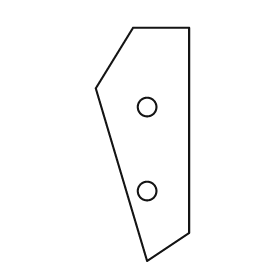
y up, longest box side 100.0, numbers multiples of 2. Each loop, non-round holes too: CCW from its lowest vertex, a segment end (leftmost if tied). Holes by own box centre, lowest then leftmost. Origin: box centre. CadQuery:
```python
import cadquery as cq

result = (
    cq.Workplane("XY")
    .moveTo(2.0, -50.0)
    .lineTo(20.0, -38.0)
    .lineTo(20.0, 50.0)
    .lineTo(-4.0, 50.0)
    .lineTo(-20.0, 24.0)
    .close()
    .moveTo(2.0, -20.0)
    .circle(4.0)
    .moveTo(2.0, 16.0)
    .circle(4.0)
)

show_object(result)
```